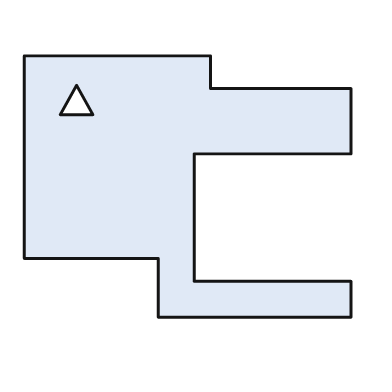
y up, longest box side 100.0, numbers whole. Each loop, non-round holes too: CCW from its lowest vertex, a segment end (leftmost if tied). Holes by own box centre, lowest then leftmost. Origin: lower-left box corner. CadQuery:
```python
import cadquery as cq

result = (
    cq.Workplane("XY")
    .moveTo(41.0, 0.0)
    .lineTo(100.0, 0.0)
    .lineTo(100.0, 11.0)
    .lineTo(52.0, 11.0)
    .lineTo(52.0, 50.0)
    .lineTo(100.0, 50.0)
    .lineTo(100.0, 70.0)
    .lineTo(57.0, 70.0)
    .lineTo(57.0, 80.0)
    .lineTo(0.0, 80.0)
    .lineTo(0.0, 18.0)
    .lineTo(41.0, 18.0)
    .close()
    .moveTo(11.0, 62.0)
    .lineTo(21.0, 62.0)
    .lineTo(16.0, 71.0)
    .close()
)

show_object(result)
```